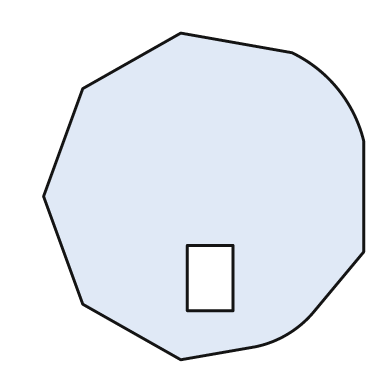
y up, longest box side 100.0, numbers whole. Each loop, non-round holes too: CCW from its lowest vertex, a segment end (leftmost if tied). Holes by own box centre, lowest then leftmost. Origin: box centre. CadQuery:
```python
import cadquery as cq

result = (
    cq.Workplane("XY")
    .moveTo(-7.0, -50.0)
    .lineTo(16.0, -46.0)
    .threePointArc((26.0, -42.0), (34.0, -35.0))
    .lineTo(49.0, -17.0)
    .lineTo(49.0, 17.0)
    .threePointArc((41.0, 33.0), (27.0, 44.0))
    .lineTo(-7.0, 50.0)
    .lineTo(-37.0, 33.0)
    .lineTo(-49.0, 0.0)
    .lineTo(-37.0, -33.0)
    .close()
    .moveTo(-5.0, -35.0)
    .lineTo(9.0, -35.0)
    .lineTo(9.0, -15.0)
    .lineTo(-5.0, -15.0)
    .close()
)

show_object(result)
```